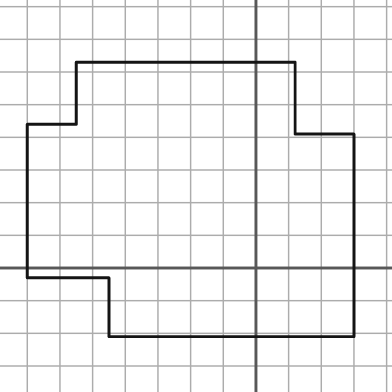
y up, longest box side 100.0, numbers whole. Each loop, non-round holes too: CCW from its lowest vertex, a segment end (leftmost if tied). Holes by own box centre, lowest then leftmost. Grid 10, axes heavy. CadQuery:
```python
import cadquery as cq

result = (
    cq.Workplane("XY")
    .moveTo(-45.0, -21.0)
    .lineTo(30.0, -21.0)
    .lineTo(30.0, 41.0)
    .lineTo(12.0, 41.0)
    .lineTo(12.0, 63.0)
    .lineTo(-55.0, 63.0)
    .lineTo(-55.0, 44.0)
    .lineTo(-70.0, 44.0)
    .lineTo(-70.0, -3.0)
    .lineTo(-45.0, -3.0)
    .close()
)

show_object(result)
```